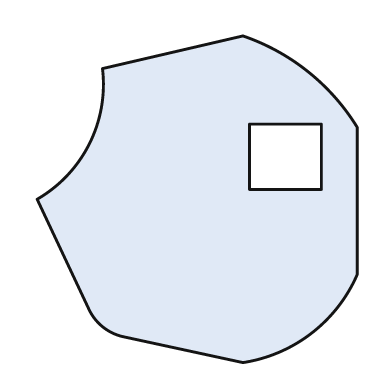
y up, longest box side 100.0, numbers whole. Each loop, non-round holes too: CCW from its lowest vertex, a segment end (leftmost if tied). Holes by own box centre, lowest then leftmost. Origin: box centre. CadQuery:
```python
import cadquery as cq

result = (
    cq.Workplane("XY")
    .moveTo(14.0, -50.0)
    .threePointArc((35.0, -41.0), (49.0, -23.0))
    .lineTo(49.0, 22.0)
    .threePointArc((34.0, 39.0), (14.0, 50.0))
    .lineTo(-29.0, 40.0)
    .threePointArc((-33.0, 17.0), (-49.0, 0.0))
    .lineTo(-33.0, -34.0)
    .threePointArc((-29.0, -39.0), (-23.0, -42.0))
    .close()
    .moveTo(16.0, 3.0)
    .lineTo(38.0, 3.0)
    .lineTo(38.0, 23.0)
    .lineTo(16.0, 23.0)
    .close()
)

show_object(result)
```